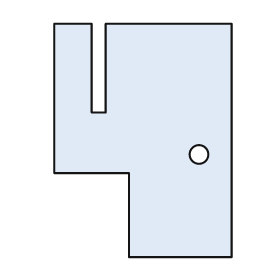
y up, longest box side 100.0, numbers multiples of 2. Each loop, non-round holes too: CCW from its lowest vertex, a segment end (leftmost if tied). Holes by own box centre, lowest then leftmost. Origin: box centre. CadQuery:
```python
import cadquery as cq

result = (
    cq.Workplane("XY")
    .moveTo(-6.0, -50.0)
    .lineTo(38.0, -50.0)
    .lineTo(38.0, 50.0)
    .lineTo(-16.0, 50.0)
    .lineTo(-16.0, 12.0)
    .lineTo(-22.0, 12.0)
    .lineTo(-22.0, 50.0)
    .lineTo(-38.0, 50.0)
    .lineTo(-38.0, -14.0)
    .lineTo(-6.0, -14.0)
    .close()
    .moveTo(24.0, -6.0)
    .circle(4.0)
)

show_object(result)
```